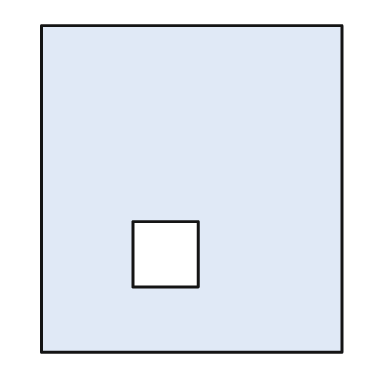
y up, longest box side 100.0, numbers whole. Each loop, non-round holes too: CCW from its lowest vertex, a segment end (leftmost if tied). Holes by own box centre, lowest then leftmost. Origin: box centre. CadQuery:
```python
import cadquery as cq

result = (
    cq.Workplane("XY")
    .moveTo(-46.0, -50.0)
    .lineTo(46.0, -50.0)
    .lineTo(46.0, 50.0)
    .lineTo(-46.0, 50.0)
    .close()
    .moveTo(-18.0, -30.0)
    .lineTo(2.0, -30.0)
    .lineTo(2.0, -10.0)
    .lineTo(-18.0, -10.0)
    .close()
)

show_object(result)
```